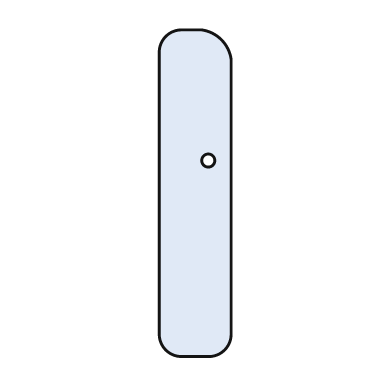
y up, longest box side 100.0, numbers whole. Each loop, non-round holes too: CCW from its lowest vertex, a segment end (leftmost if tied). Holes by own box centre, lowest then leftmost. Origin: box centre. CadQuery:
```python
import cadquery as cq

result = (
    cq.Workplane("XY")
    .moveTo(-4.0, -50.0)
    .lineTo(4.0, -50.0)
    .threePointArc((9.0, -48.0), (11.0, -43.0))
    .lineTo(11.0, 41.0)
    .threePointArc((8.0, 47.0), (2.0, 50.0))
    .lineTo(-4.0, 50.0)
    .threePointArc((-9.0, 48.0), (-11.0, 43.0))
    .lineTo(-11.0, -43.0)
    .threePointArc((-9.0, -48.0), (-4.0, -50.0))
    .close()
    .moveTo(4.0, 10.0)
    .circle(2.0)
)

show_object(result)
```